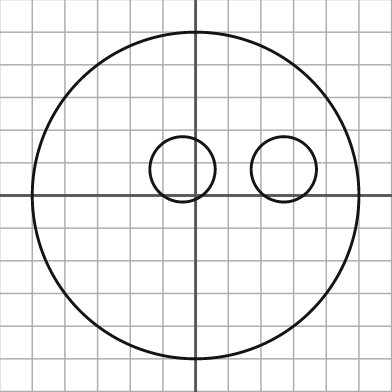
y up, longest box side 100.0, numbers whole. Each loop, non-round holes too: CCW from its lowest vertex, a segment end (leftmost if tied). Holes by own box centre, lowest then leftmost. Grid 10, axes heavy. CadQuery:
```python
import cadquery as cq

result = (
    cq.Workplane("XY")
    .moveTo(0.0, 0.0)
    .circle(50.0)
    .moveTo(-4.0, 8.0)
    .circle(10.0)
    .moveTo(27.0, 8.0)
    .circle(10.0)
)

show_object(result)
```